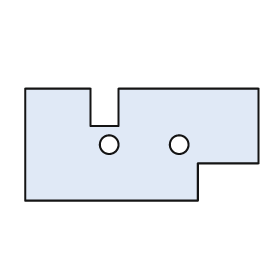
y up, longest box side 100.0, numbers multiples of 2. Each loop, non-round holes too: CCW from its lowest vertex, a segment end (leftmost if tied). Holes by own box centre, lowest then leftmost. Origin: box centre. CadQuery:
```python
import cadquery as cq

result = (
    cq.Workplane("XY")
    .moveTo(-50.0, -24.0)
    .lineTo(24.0, -24.0)
    .lineTo(24.0, -8.0)
    .lineTo(50.0, -8.0)
    .lineTo(50.0, 24.0)
    .lineTo(-10.0, 24.0)
    .lineTo(-10.0, 8.0)
    .lineTo(-22.0, 8.0)
    .lineTo(-22.0, 24.0)
    .lineTo(-50.0, 24.0)
    .close()
    .moveTo(-14.0, 0.0)
    .circle(4.0)
    .moveTo(16.0, 0.0)
    .circle(4.0)
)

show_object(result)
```